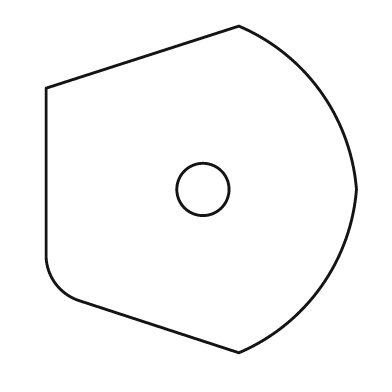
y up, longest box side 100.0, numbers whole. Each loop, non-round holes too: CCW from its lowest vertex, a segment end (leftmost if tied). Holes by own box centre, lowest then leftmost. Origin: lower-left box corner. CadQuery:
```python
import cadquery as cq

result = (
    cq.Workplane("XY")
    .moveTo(59.0, 0.0)
    .threePointArc((84.0, 20.0), (95.0, 50.0))
    .threePointArc((84.0, 80.0), (59.0, 100.0))
    .lineTo(0.0, 81.0)
    .lineTo(0.0, 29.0)
    .threePointArc((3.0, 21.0), (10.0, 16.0))
    .close()
    .moveTo(48.0, 50.0)
    .circle(8.0)
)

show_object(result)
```